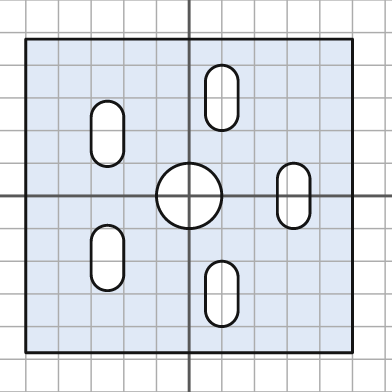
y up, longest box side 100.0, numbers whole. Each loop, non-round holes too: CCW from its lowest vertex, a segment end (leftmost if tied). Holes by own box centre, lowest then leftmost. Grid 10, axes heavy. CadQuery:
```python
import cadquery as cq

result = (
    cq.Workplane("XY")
    .moveTo(-50.0, -48.0)
    .lineTo(50.0, -48.0)
    .lineTo(50.0, 48.0)
    .lineTo(-50.0, 48.0)
    .close()
    .moveTo(5.0, -35.0)
    .threePointArc((10.0, -40.0), (15.0, -35.0))
    .lineTo(15.0, -25.0)
    .threePointArc((10.0, -20.0), (5.0, -25.0))
    .close()
    .moveTo(-30.0, -24.0)
    .threePointArc((-25.0, -29.0), (-20.0, -24.0))
    .lineTo(-20.0, -14.0)
    .threePointArc((-25.0, -9.0), (-30.0, -14.0))
    .close()
    .moveTo(0.0, 0.0)
    .circle(10.0)
    .moveTo(27.0, -5.0)
    .threePointArc((32.0, -10.0), (37.0, -5.0))
    .lineTo(37.0, 5.0)
    .threePointArc((32.0, 10.0), (27.0, 5.0))
    .close()
    .moveTo(-30.0, 14.0)
    .threePointArc((-25.0, 9.0), (-20.0, 14.0))
    .lineTo(-20.0, 24.0)
    .threePointArc((-25.0, 29.0), (-30.0, 24.0))
    .close()
    .moveTo(5.0, 25.0)
    .threePointArc((10.0, 20.0), (15.0, 25.0))
    .lineTo(15.0, 35.0)
    .threePointArc((10.0, 40.0), (5.0, 35.0))
    .close()
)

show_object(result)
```